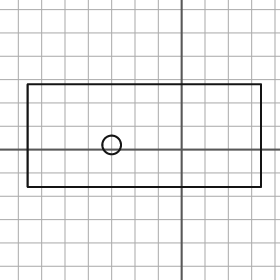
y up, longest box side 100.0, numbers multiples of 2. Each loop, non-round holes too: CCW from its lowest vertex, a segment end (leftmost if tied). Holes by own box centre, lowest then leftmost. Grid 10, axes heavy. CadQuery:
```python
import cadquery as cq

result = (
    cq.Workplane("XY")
    .moveTo(-66.0, -16.0)
    .lineTo(34.0, -16.0)
    .lineTo(34.0, 28.0)
    .lineTo(-66.0, 28.0)
    .close()
    .moveTo(-30.0, 2.0)
    .circle(4.0)
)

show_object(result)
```